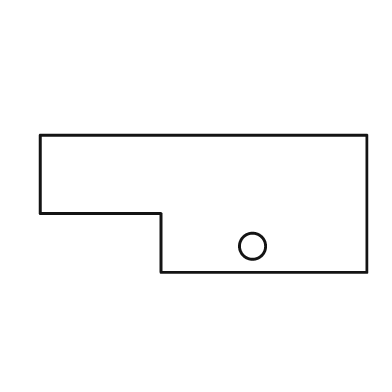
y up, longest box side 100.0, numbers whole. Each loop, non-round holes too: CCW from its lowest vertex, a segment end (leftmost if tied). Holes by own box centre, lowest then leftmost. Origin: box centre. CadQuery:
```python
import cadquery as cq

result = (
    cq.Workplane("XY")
    .moveTo(-13.0, -21.0)
    .lineTo(50.0, -21.0)
    .lineTo(50.0, 21.0)
    .lineTo(-50.0, 21.0)
    .lineTo(-50.0, -3.0)
    .lineTo(-13.0, -3.0)
    .close()
    .moveTo(15.0, -13.0)
    .circle(4.0)
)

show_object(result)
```